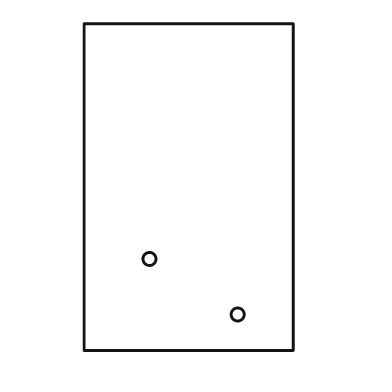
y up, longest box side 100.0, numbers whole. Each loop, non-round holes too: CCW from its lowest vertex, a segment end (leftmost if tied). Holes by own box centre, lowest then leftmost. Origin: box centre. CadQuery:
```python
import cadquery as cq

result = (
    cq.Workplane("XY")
    .moveTo(-32.0, -50.0)
    .lineTo(32.0, -50.0)
    .lineTo(32.0, 50.0)
    .lineTo(-32.0, 50.0)
    .close()
    .moveTo(15.0, -39.0)
    .circle(2.0)
    .moveTo(-12.0, -22.0)
    .circle(2.0)
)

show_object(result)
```